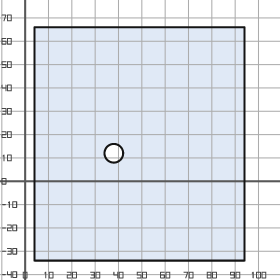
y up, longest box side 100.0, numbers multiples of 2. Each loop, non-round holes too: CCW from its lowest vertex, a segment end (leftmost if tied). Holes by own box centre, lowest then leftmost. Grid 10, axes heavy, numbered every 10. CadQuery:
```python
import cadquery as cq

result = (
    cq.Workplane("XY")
    .moveTo(4.0, -34.0)
    .lineTo(94.0, -34.0)
    .lineTo(94.0, 66.0)
    .lineTo(4.0, 66.0)
    .close()
    .moveTo(38.0, 12.0)
    .circle(4.0)
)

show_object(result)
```